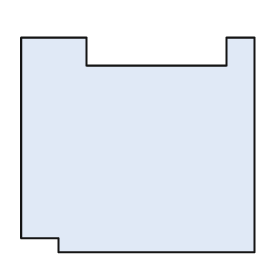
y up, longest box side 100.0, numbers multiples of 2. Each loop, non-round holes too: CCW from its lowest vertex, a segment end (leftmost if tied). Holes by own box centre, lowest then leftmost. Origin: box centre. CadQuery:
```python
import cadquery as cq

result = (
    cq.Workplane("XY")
    .moveTo(-34.0, -46.0)
    .lineTo(50.0, -46.0)
    .lineTo(50.0, 46.0)
    .lineTo(38.0, 46.0)
    .lineTo(38.0, 34.0)
    .lineTo(-22.0, 34.0)
    .lineTo(-22.0, 46.0)
    .lineTo(-50.0, 46.0)
    .lineTo(-50.0, -40.0)
    .lineTo(-34.0, -40.0)
    .close()
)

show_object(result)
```